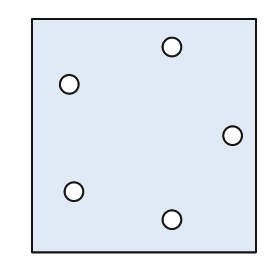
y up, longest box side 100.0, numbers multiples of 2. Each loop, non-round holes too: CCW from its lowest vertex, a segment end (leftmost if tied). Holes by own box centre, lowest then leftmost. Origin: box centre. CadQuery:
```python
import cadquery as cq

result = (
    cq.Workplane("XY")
    .moveTo(-48.0, -50.0)
    .lineTo(48.0, -50.0)
    .lineTo(48.0, 50.0)
    .lineTo(-48.0, 50.0)
    .close()
    .moveTo(12.0, -36.0)
    .circle(4.0)
    .moveTo(-30.0, -24.0)
    .circle(4.0)
    .moveTo(38.0, 0.0)
    .circle(4.0)
    .moveTo(-32.0, 22.0)
    .circle(4.0)
    .moveTo(12.0, 38.0)
    .circle(4.0)
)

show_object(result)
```